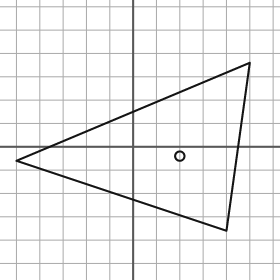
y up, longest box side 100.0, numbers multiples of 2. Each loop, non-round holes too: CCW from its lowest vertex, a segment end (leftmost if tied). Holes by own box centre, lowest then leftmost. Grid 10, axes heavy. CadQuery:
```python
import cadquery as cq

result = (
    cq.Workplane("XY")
    .moveTo(40.0, -36.0)
    .lineTo(50.0, 36.0)
    .lineTo(-50.0, -6.0)
    .close()
    .moveTo(20.0, -4.0)
    .circle(2.0)
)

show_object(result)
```